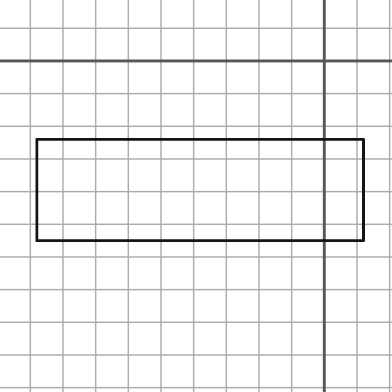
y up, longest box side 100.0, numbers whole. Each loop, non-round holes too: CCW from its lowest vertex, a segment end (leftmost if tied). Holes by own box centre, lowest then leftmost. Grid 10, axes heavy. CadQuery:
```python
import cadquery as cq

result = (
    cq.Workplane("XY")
    .moveTo(-88.0, -55.0)
    .lineTo(12.0, -55.0)
    .lineTo(12.0, -24.0)
    .lineTo(-88.0, -24.0)
    .close()
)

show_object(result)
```